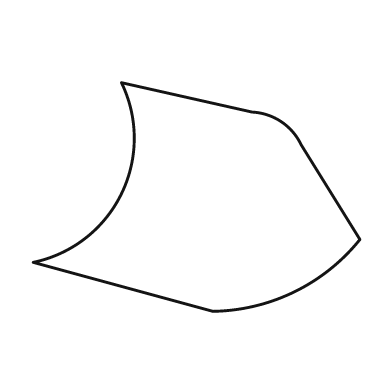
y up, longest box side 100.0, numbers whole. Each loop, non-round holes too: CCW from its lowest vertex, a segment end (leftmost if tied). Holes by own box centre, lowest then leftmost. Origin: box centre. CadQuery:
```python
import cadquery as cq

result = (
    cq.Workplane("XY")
    .moveTo(5.0, -35.0)
    .threePointArc((30.0, -29.0), (50.0, -13.0))
    .lineTo(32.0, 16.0)
    .threePointArc((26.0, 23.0), (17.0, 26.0))
    .lineTo(-23.0, 35.0)
    .threePointArc((-23.0, 1.0), (-50.0, -20.0))
    .close()
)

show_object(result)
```